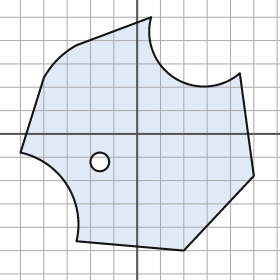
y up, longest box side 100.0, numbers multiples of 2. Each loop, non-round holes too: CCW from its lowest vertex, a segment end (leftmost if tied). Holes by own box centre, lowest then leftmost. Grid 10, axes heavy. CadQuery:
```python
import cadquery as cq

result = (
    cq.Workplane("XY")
    .moveTo(20.0, -50.0)
    .lineTo(50.0, -18.0)
    .lineTo(44.0, 26.0)
    .threePointArc((16.0, 24.0), (6.0, 50.0))
    .lineTo(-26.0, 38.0)
    .threePointArc((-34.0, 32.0), (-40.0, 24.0))
    .lineTo(-50.0, -8.0)
    .threePointArc((-30.0, -22.0), (-26.0, -46.0))
    .close()
    .moveTo(-16.0, -12.0)
    .circle(4.0)
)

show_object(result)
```